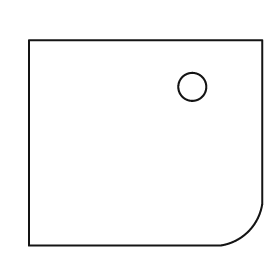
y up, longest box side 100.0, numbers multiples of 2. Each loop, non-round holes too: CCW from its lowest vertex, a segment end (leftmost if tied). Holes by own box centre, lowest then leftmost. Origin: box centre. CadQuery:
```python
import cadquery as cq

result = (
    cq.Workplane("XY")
    .moveTo(-50.0, -44.0)
    .lineTo(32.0, -44.0)
    .threePointArc((44.0, -38.0), (50.0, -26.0))
    .lineTo(50.0, 44.0)
    .lineTo(-50.0, 44.0)
    .close()
    .moveTo(20.0, 24.0)
    .circle(6.0)
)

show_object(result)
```